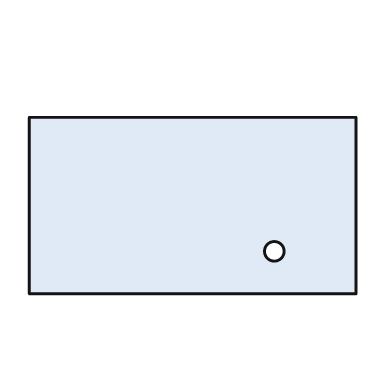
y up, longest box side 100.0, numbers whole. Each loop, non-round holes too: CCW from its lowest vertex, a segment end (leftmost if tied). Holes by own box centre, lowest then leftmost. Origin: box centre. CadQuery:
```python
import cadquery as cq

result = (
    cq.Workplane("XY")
    .moveTo(-50.0, -27.0)
    .lineTo(50.0, -27.0)
    .lineTo(50.0, 27.0)
    .lineTo(-50.0, 27.0)
    .close()
    .moveTo(25.0, -14.0)
    .circle(3.0)
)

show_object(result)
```